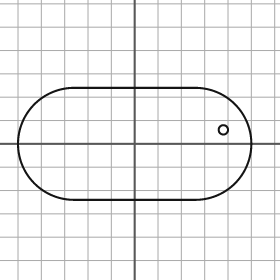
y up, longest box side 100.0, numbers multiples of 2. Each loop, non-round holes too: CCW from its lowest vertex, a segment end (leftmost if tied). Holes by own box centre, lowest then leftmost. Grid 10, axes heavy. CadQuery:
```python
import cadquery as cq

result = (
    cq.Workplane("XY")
    .moveTo(-26.0, -24.0)
    .lineTo(26.0, -24.0)
    .threePointArc((50.0, 0.0), (26.0, 24.0))
    .lineTo(-26.0, 24.0)
    .threePointArc((-50.0, 0.0), (-26.0, -24.0))
    .close()
    .moveTo(38.0, 6.0)
    .circle(2.0)
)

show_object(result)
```